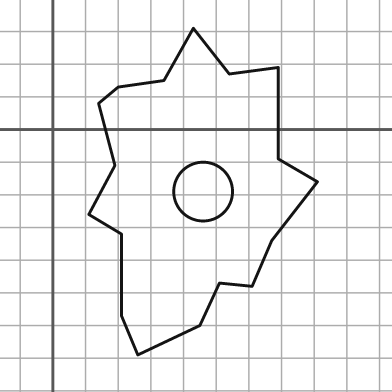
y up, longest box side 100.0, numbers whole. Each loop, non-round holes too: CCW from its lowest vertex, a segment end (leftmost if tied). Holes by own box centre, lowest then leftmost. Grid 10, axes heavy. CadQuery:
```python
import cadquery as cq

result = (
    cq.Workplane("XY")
    .moveTo(26.0, -69.0)
    .lineTo(45.0, -60.0)
    .lineTo(51.0, -47.0)
    .lineTo(61.0, -48.0)
    .lineTo(67.0, -34.0)
    .lineTo(81.0, -16.0)
    .lineTo(69.0, -9.0)
    .lineTo(69.0, 19.0)
    .lineTo(54.0, 17.0)
    .lineTo(43.0, 31.0)
    .lineTo(34.0, 15.0)
    .lineTo(20.0, 13.0)
    .lineTo(14.0, 8.0)
    .lineTo(19.0, -11.0)
    .lineTo(11.0, -26.0)
    .lineTo(21.0, -32.0)
    .lineTo(21.0, -57.0)
    .close()
    .moveTo(46.0, -19.0)
    .circle(9.0)
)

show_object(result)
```